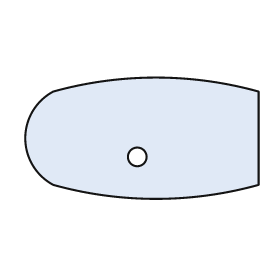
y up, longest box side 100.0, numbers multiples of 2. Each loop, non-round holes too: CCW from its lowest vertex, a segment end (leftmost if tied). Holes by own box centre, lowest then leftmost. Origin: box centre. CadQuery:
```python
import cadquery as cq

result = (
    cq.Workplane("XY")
    .moveTo(-38.0, -20.0)
    .threePointArc((6.0, -26.0), (50.0, -20.0))
    .lineTo(50.0, 20.0)
    .threePointArc((6.0, 26.0), (-38.0, 20.0))
    .threePointArc((-50.0, 0.0), (-38.0, -20.0))
    .close()
    .moveTo(-2.0, -8.0)
    .circle(4.0)
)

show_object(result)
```